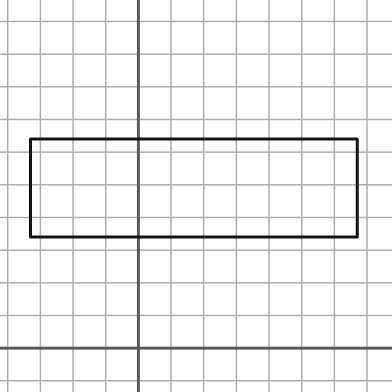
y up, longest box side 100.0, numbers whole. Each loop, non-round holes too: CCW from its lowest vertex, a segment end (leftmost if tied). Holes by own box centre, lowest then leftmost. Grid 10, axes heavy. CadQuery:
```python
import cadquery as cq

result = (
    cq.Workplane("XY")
    .moveTo(-33.0, 34.0)
    .lineTo(67.0, 34.0)
    .lineTo(67.0, 64.0)
    .lineTo(-33.0, 64.0)
    .close()
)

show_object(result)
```